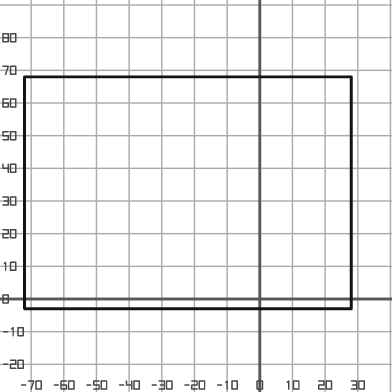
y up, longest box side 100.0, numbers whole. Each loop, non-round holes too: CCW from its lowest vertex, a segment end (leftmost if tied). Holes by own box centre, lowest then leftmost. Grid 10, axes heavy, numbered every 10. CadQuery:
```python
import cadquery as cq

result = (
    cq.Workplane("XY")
    .moveTo(-72.0, -3.0)
    .lineTo(28.0, -3.0)
    .lineTo(28.0, 68.0)
    .lineTo(-72.0, 68.0)
    .close()
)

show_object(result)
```